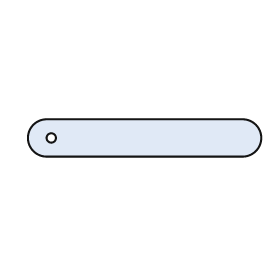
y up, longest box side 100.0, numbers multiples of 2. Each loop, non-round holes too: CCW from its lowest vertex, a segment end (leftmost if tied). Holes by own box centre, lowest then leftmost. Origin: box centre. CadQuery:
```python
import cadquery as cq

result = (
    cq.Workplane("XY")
    .moveTo(-42.0, -8.0)
    .lineTo(42.0, -8.0)
    .threePointArc((50.0, 0.0), (42.0, 8.0))
    .lineTo(-42.0, 8.0)
    .threePointArc((-50.0, 0.0), (-42.0, -8.0))
    .close()
    .moveTo(-40.0, 0.0)
    .circle(2.0)
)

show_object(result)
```